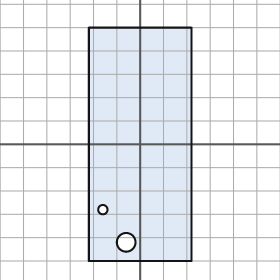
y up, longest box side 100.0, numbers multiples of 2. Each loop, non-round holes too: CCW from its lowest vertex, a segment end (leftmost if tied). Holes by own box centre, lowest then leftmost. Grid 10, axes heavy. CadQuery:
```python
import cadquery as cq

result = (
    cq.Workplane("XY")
    .moveTo(-22.0, -50.0)
    .lineTo(22.0, -50.0)
    .lineTo(22.0, 50.0)
    .lineTo(-22.0, 50.0)
    .close()
    .moveTo(-6.0, -42.0)
    .circle(4.0)
    .moveTo(-16.0, -28.0)
    .circle(2.0)
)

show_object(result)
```